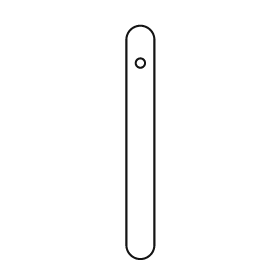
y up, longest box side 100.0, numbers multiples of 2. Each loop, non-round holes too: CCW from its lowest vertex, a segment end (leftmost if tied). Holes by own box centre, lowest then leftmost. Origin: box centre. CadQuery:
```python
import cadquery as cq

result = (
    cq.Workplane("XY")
    .moveTo(-6.0, -44.0)
    .threePointArc((0.0, -50.0), (6.0, -44.0))
    .lineTo(6.0, 44.0)
    .threePointArc((0.0, 50.0), (-6.0, 44.0))
    .close()
    .moveTo(0.0, 34.0)
    .circle(2.0)
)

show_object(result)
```